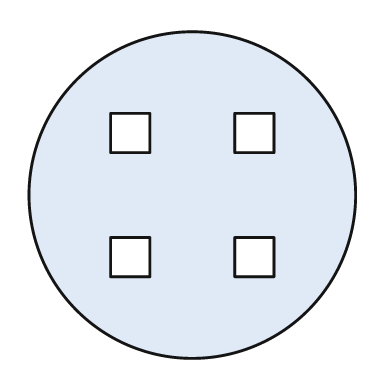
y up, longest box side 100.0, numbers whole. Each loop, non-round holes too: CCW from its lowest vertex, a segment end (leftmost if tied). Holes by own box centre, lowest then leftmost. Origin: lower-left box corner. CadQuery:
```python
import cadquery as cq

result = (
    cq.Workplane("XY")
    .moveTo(50.0, 50.0)
    .circle(50.0)
    .moveTo(25.0, 25.0)
    .lineTo(37.0, 25.0)
    .lineTo(37.0, 37.0)
    .lineTo(25.0, 37.0)
    .close()
    .moveTo(63.0, 25.0)
    .lineTo(75.0, 25.0)
    .lineTo(75.0, 37.0)
    .lineTo(63.0, 37.0)
    .close()
    .moveTo(25.0, 63.0)
    .lineTo(37.0, 63.0)
    .lineTo(37.0, 75.0)
    .lineTo(25.0, 75.0)
    .close()
    .moveTo(63.0, 63.0)
    .lineTo(75.0, 63.0)
    .lineTo(75.0, 75.0)
    .lineTo(63.0, 75.0)
    .close()
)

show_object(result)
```